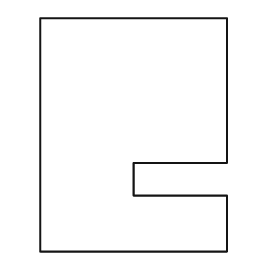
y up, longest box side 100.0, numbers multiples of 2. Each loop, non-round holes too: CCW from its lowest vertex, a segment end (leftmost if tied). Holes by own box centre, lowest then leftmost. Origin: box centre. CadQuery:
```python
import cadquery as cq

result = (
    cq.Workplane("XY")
    .moveTo(-40.0, -50.0)
    .lineTo(40.0, -50.0)
    .lineTo(40.0, -26.0)
    .lineTo(0.0, -26.0)
    .lineTo(0.0, -12.0)
    .lineTo(40.0, -12.0)
    .lineTo(40.0, 50.0)
    .lineTo(-40.0, 50.0)
    .close()
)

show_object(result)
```